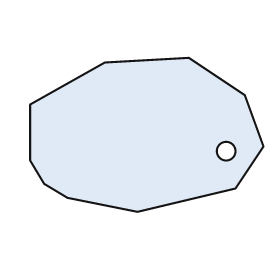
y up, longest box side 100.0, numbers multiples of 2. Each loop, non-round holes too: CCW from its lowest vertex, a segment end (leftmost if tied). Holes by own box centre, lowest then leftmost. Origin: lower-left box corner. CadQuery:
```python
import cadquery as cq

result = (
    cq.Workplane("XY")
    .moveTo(46.0, 0.0)
    .lineTo(88.0, 10.0)
    .lineTo(100.0, 28.0)
    .lineTo(92.0, 50.0)
    .lineTo(68.0, 66.0)
    .lineTo(32.0, 64.0)
    .lineTo(0.0, 46.0)
    .lineTo(0.0, 22.0)
    .lineTo(6.0, 12.0)
    .lineTo(16.0, 6.0)
    .close()
    .moveTo(84.0, 26.0)
    .circle(4.0)
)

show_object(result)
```